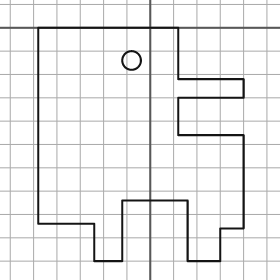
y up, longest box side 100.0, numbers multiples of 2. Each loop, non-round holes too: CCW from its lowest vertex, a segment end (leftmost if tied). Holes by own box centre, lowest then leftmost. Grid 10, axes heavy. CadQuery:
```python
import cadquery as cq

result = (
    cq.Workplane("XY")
    .moveTo(-24.0, -100.0)
    .lineTo(-12.0, -100.0)
    .lineTo(-12.0, -74.0)
    .lineTo(16.0, -74.0)
    .lineTo(16.0, -100.0)
    .lineTo(30.0, -100.0)
    .lineTo(30.0, -86.0)
    .lineTo(40.0, -86.0)
    .lineTo(40.0, -46.0)
    .lineTo(12.0, -46.0)
    .lineTo(12.0, -30.0)
    .lineTo(40.0, -30.0)
    .lineTo(40.0, -22.0)
    .lineTo(12.0, -22.0)
    .lineTo(12.0, 0.0)
    .lineTo(-48.0, 0.0)
    .lineTo(-48.0, -84.0)
    .lineTo(-24.0, -84.0)
    .close()
    .moveTo(-8.0, -14.0)
    .circle(4.0)
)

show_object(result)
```